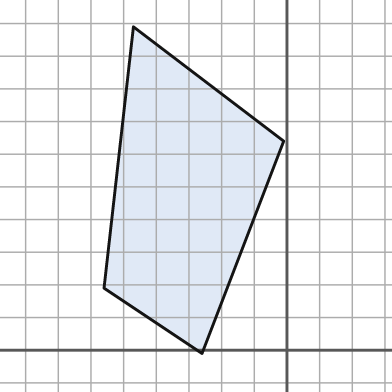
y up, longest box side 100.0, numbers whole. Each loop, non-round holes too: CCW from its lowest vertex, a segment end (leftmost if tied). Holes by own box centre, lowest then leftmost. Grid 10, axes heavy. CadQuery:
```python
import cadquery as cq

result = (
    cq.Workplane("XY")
    .moveTo(-26.0, -1.0)
    .lineTo(-1.0, 64.0)
    .lineTo(-47.0, 99.0)
    .lineTo(-56.0, 19.0)
    .close()
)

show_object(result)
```